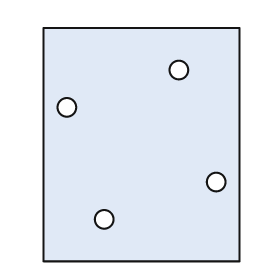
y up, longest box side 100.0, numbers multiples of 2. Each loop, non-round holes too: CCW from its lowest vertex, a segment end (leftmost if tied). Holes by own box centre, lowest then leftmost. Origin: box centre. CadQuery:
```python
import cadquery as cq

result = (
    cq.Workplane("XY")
    .moveTo(-42.0, -50.0)
    .lineTo(42.0, -50.0)
    .lineTo(42.0, 50.0)
    .lineTo(-42.0, 50.0)
    .close()
    .moveTo(-16.0, -32.0)
    .circle(4.0)
    .moveTo(32.0, -16.0)
    .circle(4.0)
    .moveTo(-32.0, 16.0)
    .circle(4.0)
    .moveTo(16.0, 32.0)
    .circle(4.0)
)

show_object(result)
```